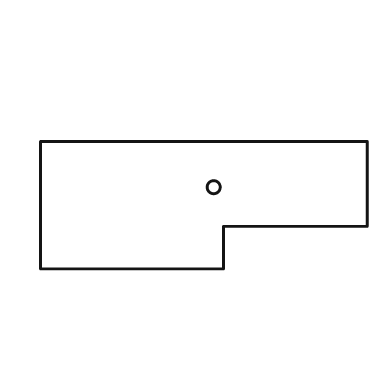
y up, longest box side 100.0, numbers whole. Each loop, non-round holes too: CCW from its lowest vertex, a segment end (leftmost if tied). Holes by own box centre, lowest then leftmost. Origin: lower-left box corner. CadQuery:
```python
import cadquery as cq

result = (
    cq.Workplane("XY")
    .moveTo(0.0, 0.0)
    .lineTo(56.0, 0.0)
    .lineTo(56.0, 13.0)
    .lineTo(100.0, 13.0)
    .lineTo(100.0, 39.0)
    .lineTo(0.0, 39.0)
    .close()
    .moveTo(53.0, 25.0)
    .circle(2.0)
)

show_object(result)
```